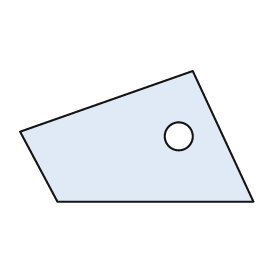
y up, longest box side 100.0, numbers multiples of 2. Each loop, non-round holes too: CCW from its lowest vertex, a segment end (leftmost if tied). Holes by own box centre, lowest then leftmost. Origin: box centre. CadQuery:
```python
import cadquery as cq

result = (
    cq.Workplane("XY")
    .moveTo(-34.0, -28.0)
    .lineTo(50.0, -28.0)
    .lineTo(24.0, 28.0)
    .lineTo(-50.0, 2.0)
    .close()
    .moveTo(18.0, 0.0)
    .circle(6.0)
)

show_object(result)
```